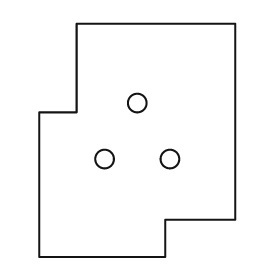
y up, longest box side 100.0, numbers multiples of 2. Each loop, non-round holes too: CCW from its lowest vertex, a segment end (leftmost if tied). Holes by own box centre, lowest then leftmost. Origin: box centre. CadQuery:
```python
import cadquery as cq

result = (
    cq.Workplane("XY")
    .moveTo(-42.0, -50.0)
    .lineTo(12.0, -50.0)
    .lineTo(12.0, -34.0)
    .lineTo(42.0, -34.0)
    .lineTo(42.0, 50.0)
    .lineTo(-26.0, 50.0)
    .lineTo(-26.0, 12.0)
    .lineTo(-42.0, 12.0)
    .close()
    .moveTo(-14.0, -8.0)
    .circle(4.0)
    .moveTo(14.0, -8.0)
    .circle(4.0)
    .moveTo(0.0, 16.0)
    .circle(4.0)
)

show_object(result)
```